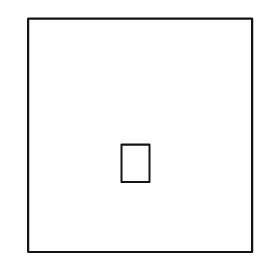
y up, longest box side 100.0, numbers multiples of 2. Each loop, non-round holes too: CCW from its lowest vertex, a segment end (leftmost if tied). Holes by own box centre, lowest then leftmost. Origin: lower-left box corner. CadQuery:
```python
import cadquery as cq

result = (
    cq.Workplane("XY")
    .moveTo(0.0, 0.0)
    .lineTo(96.0, 0.0)
    .lineTo(96.0, 100.0)
    .lineTo(0.0, 100.0)
    .close()
    .moveTo(40.0, 30.0)
    .lineTo(52.0, 30.0)
    .lineTo(52.0, 46.0)
    .lineTo(40.0, 46.0)
    .close()
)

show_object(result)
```